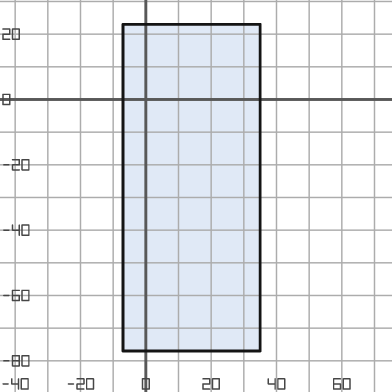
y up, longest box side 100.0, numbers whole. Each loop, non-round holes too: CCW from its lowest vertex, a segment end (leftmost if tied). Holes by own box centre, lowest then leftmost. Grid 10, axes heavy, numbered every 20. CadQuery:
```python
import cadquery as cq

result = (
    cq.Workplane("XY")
    .moveTo(-7.0, -77.0)
    .lineTo(35.0, -77.0)
    .lineTo(35.0, 23.0)
    .lineTo(-7.0, 23.0)
    .close()
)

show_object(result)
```